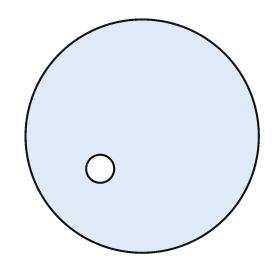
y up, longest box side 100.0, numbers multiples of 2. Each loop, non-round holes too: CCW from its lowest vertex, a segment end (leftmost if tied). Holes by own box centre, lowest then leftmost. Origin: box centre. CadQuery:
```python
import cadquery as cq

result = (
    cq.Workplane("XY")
    .moveTo(0.0, 0.0)
    .circle(50.0)
    .moveTo(-18.0, -14.0)
    .circle(6.0)
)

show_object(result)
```